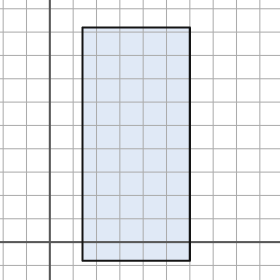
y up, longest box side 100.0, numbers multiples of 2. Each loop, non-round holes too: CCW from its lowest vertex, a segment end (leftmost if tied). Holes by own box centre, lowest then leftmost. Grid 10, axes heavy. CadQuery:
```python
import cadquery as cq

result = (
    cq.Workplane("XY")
    .moveTo(14.0, -8.0)
    .lineTo(60.0, -8.0)
    .lineTo(60.0, 92.0)
    .lineTo(14.0, 92.0)
    .close()
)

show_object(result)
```